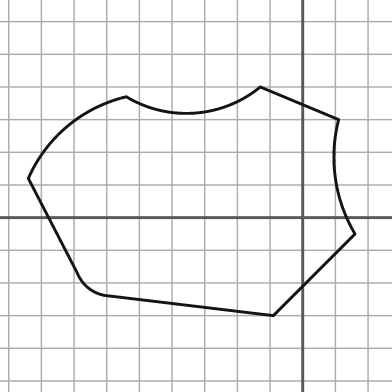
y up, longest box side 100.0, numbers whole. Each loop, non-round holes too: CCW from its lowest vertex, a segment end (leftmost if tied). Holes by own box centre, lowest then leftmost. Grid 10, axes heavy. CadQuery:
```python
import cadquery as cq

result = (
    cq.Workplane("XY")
    .moveTo(-9.0, -30.0)
    .lineTo(16.0, -5.0)
    .threePointArc((10.0, 12.0), (11.0, 30.0))
    .lineTo(-13.0, 40.0)
    .threePointArc((-33.0, 32.0), (-54.0, 37.0))
    .threePointArc((-72.0, 28.0), (-84.0, 12.0))
    .lineTo(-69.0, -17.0)
    .threePointArc((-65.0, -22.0), (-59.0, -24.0))
    .close()
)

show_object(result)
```